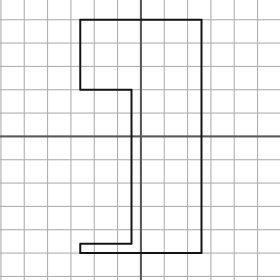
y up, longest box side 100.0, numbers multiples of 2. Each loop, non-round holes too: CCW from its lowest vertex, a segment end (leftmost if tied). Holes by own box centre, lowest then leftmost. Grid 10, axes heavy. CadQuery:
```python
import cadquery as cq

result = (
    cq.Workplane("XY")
    .moveTo(-26.0, -50.0)
    .lineTo(26.0, -50.0)
    .lineTo(26.0, 50.0)
    .lineTo(-26.0, 50.0)
    .lineTo(-26.0, 20.0)
    .lineTo(-4.0, 20.0)
    .lineTo(-4.0, -46.0)
    .lineTo(-26.0, -46.0)
    .close()
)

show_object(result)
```